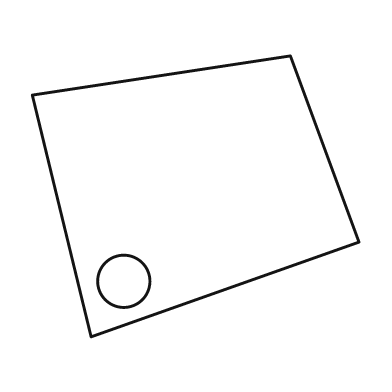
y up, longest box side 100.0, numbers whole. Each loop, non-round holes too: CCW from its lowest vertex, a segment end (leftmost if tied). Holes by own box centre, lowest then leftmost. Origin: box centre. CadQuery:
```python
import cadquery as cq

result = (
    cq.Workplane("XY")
    .moveTo(-32.0, -43.0)
    .lineTo(50.0, -14.0)
    .lineTo(29.0, 43.0)
    .lineTo(-50.0, 31.0)
    .close()
    .moveTo(-22.0, -26.0)
    .circle(8.0)
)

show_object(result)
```